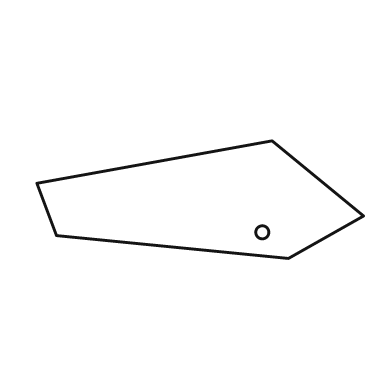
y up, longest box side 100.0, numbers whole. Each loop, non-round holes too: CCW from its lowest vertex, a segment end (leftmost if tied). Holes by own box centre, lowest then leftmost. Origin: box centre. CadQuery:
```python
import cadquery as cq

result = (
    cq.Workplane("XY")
    .moveTo(27.0, -18.0)
    .lineTo(50.0, -5.0)
    .lineTo(22.0, 18.0)
    .lineTo(-50.0, 5.0)
    .lineTo(-44.0, -11.0)
    .close()
    .moveTo(19.0, -10.0)
    .circle(2.0)
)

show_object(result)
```